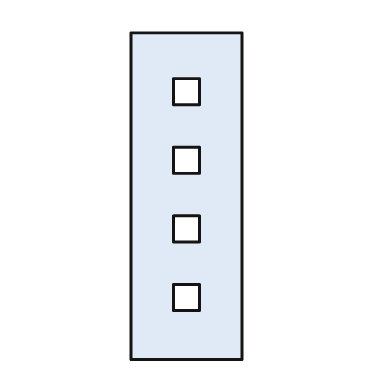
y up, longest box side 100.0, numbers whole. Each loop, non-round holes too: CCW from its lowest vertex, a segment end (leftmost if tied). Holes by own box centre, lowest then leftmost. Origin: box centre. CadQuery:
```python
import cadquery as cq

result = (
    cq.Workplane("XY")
    .moveTo(-17.0, -50.0)
    .lineTo(17.0, -50.0)
    .lineTo(17.0, 50.0)
    .lineTo(-17.0, 50.0)
    .close()
    .moveTo(-4.0, -35.0)
    .lineTo(4.0, -35.0)
    .lineTo(4.0, -27.0)
    .lineTo(-4.0, -27.0)
    .close()
    .moveTo(-4.0, -14.0)
    .lineTo(4.0, -14.0)
    .lineTo(4.0, -6.0)
    .lineTo(-4.0, -6.0)
    .close()
    .moveTo(-4.0, 7.0)
    .lineTo(4.0, 7.0)
    .lineTo(4.0, 15.0)
    .lineTo(-4.0, 15.0)
    .close()
    .moveTo(-4.0, 28.0)
    .lineTo(4.0, 28.0)
    .lineTo(4.0, 36.0)
    .lineTo(-4.0, 36.0)
    .close()
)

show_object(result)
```